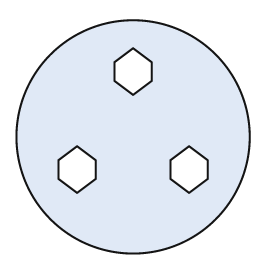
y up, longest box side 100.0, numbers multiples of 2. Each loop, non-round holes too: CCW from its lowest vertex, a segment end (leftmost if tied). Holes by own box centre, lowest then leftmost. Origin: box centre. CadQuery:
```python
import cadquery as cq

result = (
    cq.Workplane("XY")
    .moveTo(0.0, 0.0)
    .circle(50.0)
    .moveTo(-24.0, -24.0)
    .lineTo(-16.0, -18.0)
    .lineTo(-16.0, -10.0)
    .lineTo(-24.0, -4.0)
    .lineTo(-32.0, -10.0)
    .lineTo(-32.0, -18.0)
    .close()
    .moveTo(24.0, -24.0)
    .lineTo(32.0, -18.0)
    .lineTo(32.0, -10.0)
    .lineTo(24.0, -4.0)
    .lineTo(16.0, -10.0)
    .lineTo(16.0, -18.0)
    .close()
    .moveTo(0.0, 18.0)
    .lineTo(8.0, 24.0)
    .lineTo(8.0, 32.0)
    .lineTo(0.0, 38.0)
    .lineTo(-8.0, 32.0)
    .lineTo(-8.0, 24.0)
    .close()
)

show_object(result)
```